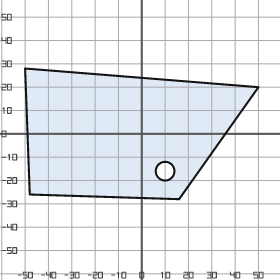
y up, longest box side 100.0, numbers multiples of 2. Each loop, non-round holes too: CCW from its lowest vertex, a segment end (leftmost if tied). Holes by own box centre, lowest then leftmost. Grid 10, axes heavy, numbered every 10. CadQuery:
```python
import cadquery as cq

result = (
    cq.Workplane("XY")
    .moveTo(16.0, -28.0)
    .lineTo(50.0, 20.0)
    .lineTo(-50.0, 28.0)
    .lineTo(-48.0, -26.0)
    .close()
    .moveTo(10.0, -16.0)
    .circle(4.0)
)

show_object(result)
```